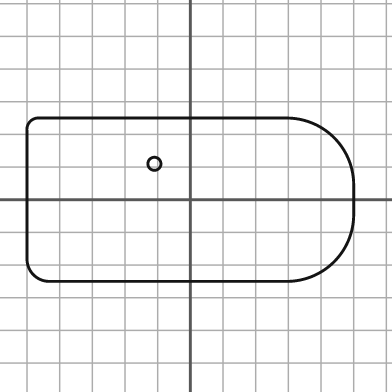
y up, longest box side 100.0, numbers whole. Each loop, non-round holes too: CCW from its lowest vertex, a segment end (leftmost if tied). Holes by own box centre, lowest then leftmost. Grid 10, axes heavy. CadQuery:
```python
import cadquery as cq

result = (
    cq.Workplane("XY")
    .moveTo(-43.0, -25.0)
    .lineTo(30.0, -25.0)
    .threePointArc((44.0, -19.0), (50.0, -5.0))
    .lineTo(50.0, 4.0)
    .threePointArc((44.0, 19.0), (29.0, 25.0))
    .lineTo(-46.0, 25.0)
    .threePointArc((-49.0, 24.0), (-50.0, 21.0))
    .lineTo(-50.0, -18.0)
    .threePointArc((-48.0, -23.0), (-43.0, -25.0))
    .close()
    .moveTo(-11.0, 11.0)
    .circle(2.0)
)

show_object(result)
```